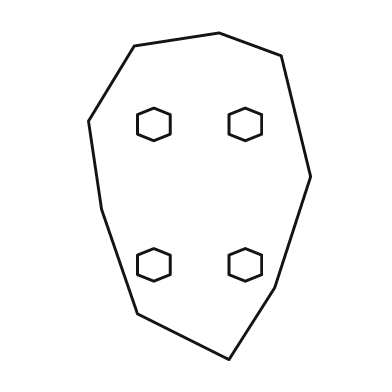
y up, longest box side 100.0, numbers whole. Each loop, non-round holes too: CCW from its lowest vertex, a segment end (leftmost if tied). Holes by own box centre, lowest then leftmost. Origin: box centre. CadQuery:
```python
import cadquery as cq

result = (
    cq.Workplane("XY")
    .moveTo(9.0, -50.0)
    .lineTo(23.0, -28.0)
    .lineTo(34.0, 6.0)
    .lineTo(25.0, 43.0)
    .lineTo(6.0, 50.0)
    .lineTo(-20.0, 46.0)
    .lineTo(-34.0, 23.0)
    .lineTo(-30.0, -4.0)
    .lineTo(-19.0, -36.0)
    .close()
    .moveTo(-14.0, -26.0)
    .lineTo(-9.0, -24.0)
    .lineTo(-9.0, -18.0)
    .lineTo(-14.0, -16.0)
    .lineTo(-19.0, -18.0)
    .lineTo(-19.0, -24.0)
    .close()
    .moveTo(14.0, -26.0)
    .lineTo(19.0, -24.0)
    .lineTo(19.0, -18.0)
    .lineTo(14.0, -16.0)
    .lineTo(9.0, -18.0)
    .lineTo(9.0, -24.0)
    .close()
    .moveTo(-14.0, 17.0)
    .lineTo(-9.0, 19.0)
    .lineTo(-9.0, 25.0)
    .lineTo(-14.0, 27.0)
    .lineTo(-19.0, 25.0)
    .lineTo(-19.0, 19.0)
    .close()
    .moveTo(14.0, 17.0)
    .lineTo(19.0, 19.0)
    .lineTo(19.0, 25.0)
    .lineTo(14.0, 27.0)
    .lineTo(9.0, 25.0)
    .lineTo(9.0, 19.0)
    .close()
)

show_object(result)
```